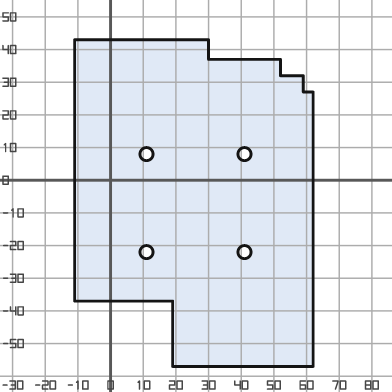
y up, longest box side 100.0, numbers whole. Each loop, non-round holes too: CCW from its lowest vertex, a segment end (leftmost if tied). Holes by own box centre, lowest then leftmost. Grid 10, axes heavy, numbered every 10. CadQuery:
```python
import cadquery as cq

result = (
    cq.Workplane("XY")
    .moveTo(19.0, -57.0)
    .lineTo(62.0, -57.0)
    .lineTo(62.0, 27.0)
    .lineTo(59.0, 27.0)
    .lineTo(59.0, 32.0)
    .lineTo(52.0, 32.0)
    .lineTo(52.0, 37.0)
    .lineTo(30.0, 37.0)
    .lineTo(30.0, 43.0)
    .lineTo(-11.0, 43.0)
    .lineTo(-11.0, -37.0)
    .lineTo(19.0, -37.0)
    .close()
    .moveTo(11.0, -22.0)
    .circle(2.0)
    .moveTo(41.0, -22.0)
    .circle(2.0)
    .moveTo(11.0, 8.0)
    .circle(2.0)
    .moveTo(41.0, 8.0)
    .circle(2.0)
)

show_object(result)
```